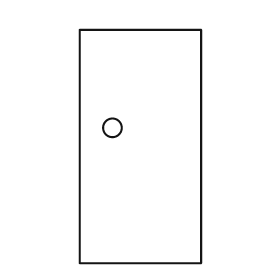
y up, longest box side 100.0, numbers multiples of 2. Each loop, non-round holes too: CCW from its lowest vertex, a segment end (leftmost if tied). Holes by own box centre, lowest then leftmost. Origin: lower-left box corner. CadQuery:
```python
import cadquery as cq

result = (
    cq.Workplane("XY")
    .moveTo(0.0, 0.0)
    .lineTo(52.0, 0.0)
    .lineTo(52.0, 100.0)
    .lineTo(0.0, 100.0)
    .close()
    .moveTo(14.0, 58.0)
    .circle(4.0)
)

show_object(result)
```